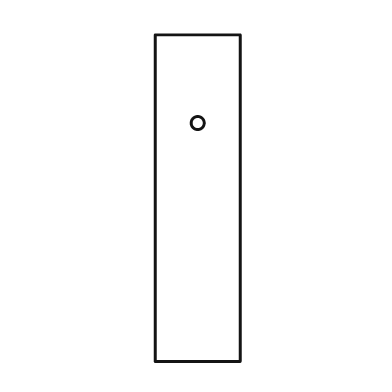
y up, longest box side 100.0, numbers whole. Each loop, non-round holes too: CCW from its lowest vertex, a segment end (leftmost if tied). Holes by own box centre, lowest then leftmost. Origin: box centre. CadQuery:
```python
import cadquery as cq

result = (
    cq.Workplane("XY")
    .moveTo(-13.0, -50.0)
    .lineTo(13.0, -50.0)
    .lineTo(13.0, 50.0)
    .lineTo(-13.0, 50.0)
    .close()
    .moveTo(0.0, 23.0)
    .circle(2.0)
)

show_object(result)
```